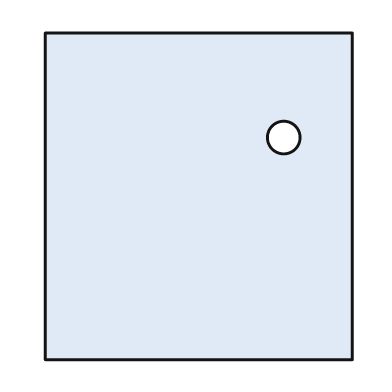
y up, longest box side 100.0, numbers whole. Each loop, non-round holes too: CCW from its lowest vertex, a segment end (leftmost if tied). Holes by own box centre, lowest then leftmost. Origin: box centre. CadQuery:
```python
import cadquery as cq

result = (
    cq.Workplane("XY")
    .moveTo(-47.0, -50.0)
    .lineTo(47.0, -50.0)
    .lineTo(47.0, 50.0)
    .lineTo(-47.0, 50.0)
    .close()
    .moveTo(26.0, 18.0)
    .circle(5.0)
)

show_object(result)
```